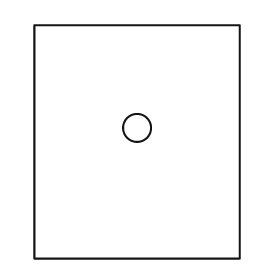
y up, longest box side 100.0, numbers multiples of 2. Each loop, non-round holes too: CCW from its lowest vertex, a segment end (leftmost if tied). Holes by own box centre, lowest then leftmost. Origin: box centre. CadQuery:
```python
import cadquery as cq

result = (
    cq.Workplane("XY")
    .moveTo(-44.0, -50.0)
    .lineTo(44.0, -50.0)
    .lineTo(44.0, 50.0)
    .lineTo(-44.0, 50.0)
    .close()
    .moveTo(0.0, 6.0)
    .circle(6.0)
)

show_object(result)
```